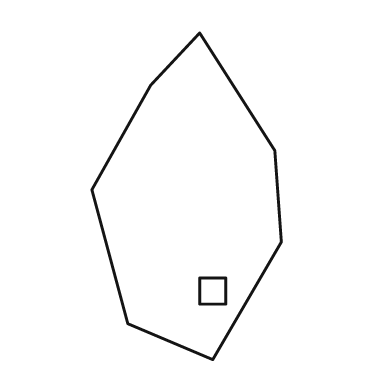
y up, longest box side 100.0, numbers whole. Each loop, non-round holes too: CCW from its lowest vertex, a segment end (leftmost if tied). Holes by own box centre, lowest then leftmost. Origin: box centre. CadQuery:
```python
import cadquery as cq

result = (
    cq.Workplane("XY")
    .moveTo(8.0, -50.0)
    .lineTo(29.0, -14.0)
    .lineTo(27.0, 14.0)
    .lineTo(4.0, 50.0)
    .lineTo(-11.0, 34.0)
    .lineTo(-29.0, 2.0)
    .lineTo(-18.0, -39.0)
    .close()
    .moveTo(4.0, -33.0)
    .lineTo(12.0, -33.0)
    .lineTo(12.0, -25.0)
    .lineTo(4.0, -25.0)
    .close()
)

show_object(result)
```